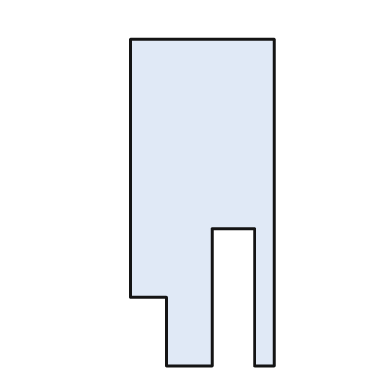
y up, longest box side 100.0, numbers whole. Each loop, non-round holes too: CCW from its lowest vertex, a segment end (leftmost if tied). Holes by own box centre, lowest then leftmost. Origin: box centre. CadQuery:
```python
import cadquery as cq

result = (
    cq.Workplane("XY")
    .moveTo(-11.0, -50.0)
    .lineTo(3.0, -50.0)
    .lineTo(3.0, -8.0)
    .lineTo(16.0, -8.0)
    .lineTo(16.0, -50.0)
    .lineTo(22.0, -50.0)
    .lineTo(22.0, 50.0)
    .lineTo(-22.0, 50.0)
    .lineTo(-22.0, -29.0)
    .lineTo(-11.0, -29.0)
    .close()
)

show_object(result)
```